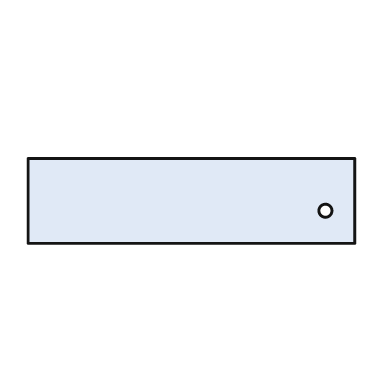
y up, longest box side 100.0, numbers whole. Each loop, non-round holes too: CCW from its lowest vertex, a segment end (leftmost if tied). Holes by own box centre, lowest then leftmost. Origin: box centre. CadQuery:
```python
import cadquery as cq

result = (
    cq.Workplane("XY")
    .moveTo(-50.0, -13.0)
    .lineTo(50.0, -13.0)
    .lineTo(50.0, 13.0)
    .lineTo(-50.0, 13.0)
    .close()
    .moveTo(41.0, -3.0)
    .circle(2.0)
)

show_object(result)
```